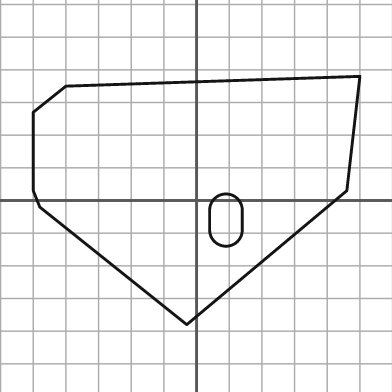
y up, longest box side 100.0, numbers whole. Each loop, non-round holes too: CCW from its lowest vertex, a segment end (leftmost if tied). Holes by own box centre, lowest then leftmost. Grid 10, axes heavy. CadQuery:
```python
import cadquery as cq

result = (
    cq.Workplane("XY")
    .moveTo(-3.0, -38.0)
    .lineTo(46.0, 3.0)
    .lineTo(50.0, 38.0)
    .lineTo(-40.0, 35.0)
    .lineTo(-50.0, 27.0)
    .lineTo(-50.0, 3.0)
    .lineTo(-48.0, -2.0)
    .close()
    .moveTo(4.0, -9.0)
    .threePointArc((9.0, -14.0), (14.0, -9.0))
    .lineTo(14.0, -3.0)
    .threePointArc((9.0, 2.0), (4.0, -3.0))
    .close()
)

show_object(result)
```